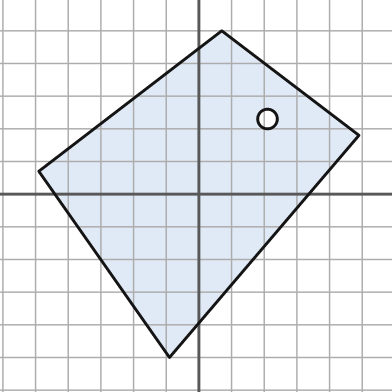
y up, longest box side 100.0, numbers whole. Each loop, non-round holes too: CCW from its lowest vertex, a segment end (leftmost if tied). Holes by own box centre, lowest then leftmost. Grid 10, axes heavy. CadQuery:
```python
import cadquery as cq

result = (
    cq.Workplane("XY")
    .moveTo(-9.0, -50.0)
    .lineTo(49.0, 18.0)
    .lineTo(7.0, 50.0)
    .lineTo(-49.0, 7.0)
    .close()
    .moveTo(21.0, 23.0)
    .circle(3.0)
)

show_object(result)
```